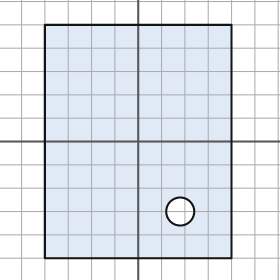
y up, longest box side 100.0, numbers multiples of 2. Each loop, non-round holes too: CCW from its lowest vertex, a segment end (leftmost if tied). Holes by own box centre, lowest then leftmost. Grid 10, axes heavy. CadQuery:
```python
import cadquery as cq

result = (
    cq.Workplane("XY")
    .moveTo(-40.0, -50.0)
    .lineTo(40.0, -50.0)
    .lineTo(40.0, 50.0)
    .lineTo(-40.0, 50.0)
    .close()
    .moveTo(18.0, -30.0)
    .circle(6.0)
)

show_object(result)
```